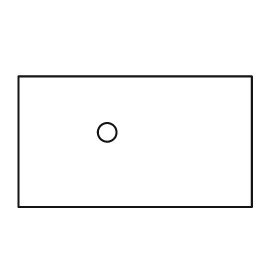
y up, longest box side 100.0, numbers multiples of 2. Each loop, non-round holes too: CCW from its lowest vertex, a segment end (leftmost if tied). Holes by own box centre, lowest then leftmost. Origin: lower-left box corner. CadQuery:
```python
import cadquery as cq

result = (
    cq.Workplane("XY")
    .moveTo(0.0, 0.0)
    .lineTo(100.0, 0.0)
    .lineTo(100.0, 56.0)
    .lineTo(0.0, 56.0)
    .close()
    .moveTo(38.0, 32.0)
    .circle(4.0)
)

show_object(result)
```